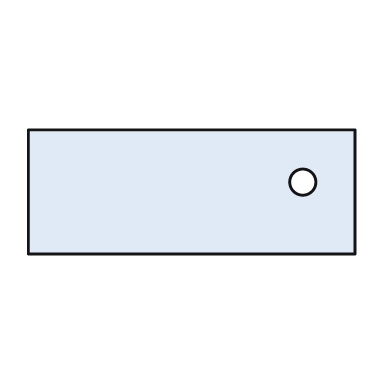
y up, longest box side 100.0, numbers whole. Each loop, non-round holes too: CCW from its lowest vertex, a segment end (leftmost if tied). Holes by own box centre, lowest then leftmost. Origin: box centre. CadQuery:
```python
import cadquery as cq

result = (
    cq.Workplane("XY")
    .moveTo(-50.0, -19.0)
    .lineTo(50.0, -19.0)
    .lineTo(50.0, 19.0)
    .lineTo(-50.0, 19.0)
    .close()
    .moveTo(34.0, 3.0)
    .circle(4.0)
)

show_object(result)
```